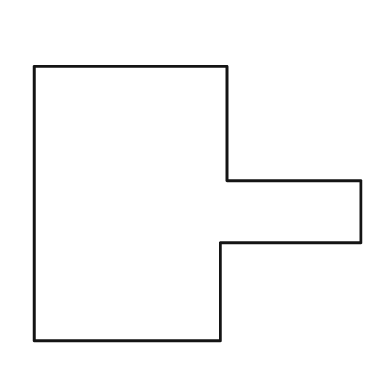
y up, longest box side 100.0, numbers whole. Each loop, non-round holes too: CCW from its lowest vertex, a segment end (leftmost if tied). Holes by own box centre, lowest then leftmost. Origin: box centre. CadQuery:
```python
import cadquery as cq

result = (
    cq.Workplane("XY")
    .moveTo(-50.0, -42.0)
    .lineTo(7.0, -42.0)
    .lineTo(7.0, -12.0)
    .lineTo(50.0, -12.0)
    .lineTo(50.0, 7.0)
    .lineTo(9.0, 7.0)
    .lineTo(9.0, 42.0)
    .lineTo(-50.0, 42.0)
    .close()
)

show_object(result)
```